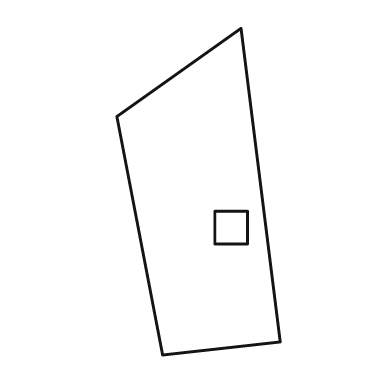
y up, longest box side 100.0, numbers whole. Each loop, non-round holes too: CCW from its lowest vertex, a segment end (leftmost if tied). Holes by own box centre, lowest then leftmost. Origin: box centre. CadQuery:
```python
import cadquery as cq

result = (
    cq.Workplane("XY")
    .moveTo(-11.0, -50.0)
    .lineTo(25.0, -46.0)
    .lineTo(13.0, 50.0)
    .lineTo(-25.0, 23.0)
    .close()
    .moveTo(5.0, -16.0)
    .lineTo(15.0, -16.0)
    .lineTo(15.0, -6.0)
    .lineTo(5.0, -6.0)
    .close()
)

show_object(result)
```